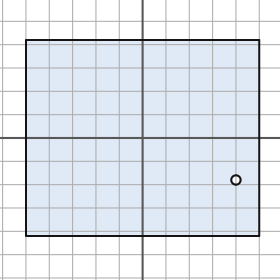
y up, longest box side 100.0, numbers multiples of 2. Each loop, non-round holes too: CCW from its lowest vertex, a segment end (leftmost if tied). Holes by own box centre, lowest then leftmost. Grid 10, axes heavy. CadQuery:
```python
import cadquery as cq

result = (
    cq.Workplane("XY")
    .moveTo(-50.0, -42.0)
    .lineTo(50.0, -42.0)
    .lineTo(50.0, 42.0)
    .lineTo(-50.0, 42.0)
    .close()
    .moveTo(40.0, -18.0)
    .circle(2.0)
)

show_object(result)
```